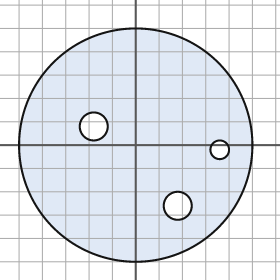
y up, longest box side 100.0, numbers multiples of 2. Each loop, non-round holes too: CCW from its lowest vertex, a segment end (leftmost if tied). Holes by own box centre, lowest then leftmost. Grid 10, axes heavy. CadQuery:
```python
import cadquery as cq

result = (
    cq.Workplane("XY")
    .moveTo(0.0, 0.0)
    .circle(50.0)
    .moveTo(18.0, -26.0)
    .circle(6.0)
    .moveTo(36.0, -2.0)
    .circle(4.0)
    .moveTo(-18.0, 8.0)
    .circle(6.0)
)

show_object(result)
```